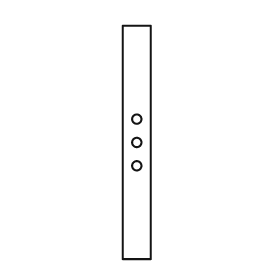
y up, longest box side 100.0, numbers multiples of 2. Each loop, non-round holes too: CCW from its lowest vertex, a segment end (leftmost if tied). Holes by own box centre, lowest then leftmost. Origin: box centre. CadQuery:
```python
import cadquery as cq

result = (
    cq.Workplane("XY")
    .moveTo(-6.0, -50.0)
    .lineTo(6.0, -50.0)
    .lineTo(6.0, 50.0)
    .lineTo(-6.0, 50.0)
    .close()
    .moveTo(0.0, -10.0)
    .circle(2.0)
    .moveTo(0.0, 0.0)
    .circle(2.0)
    .moveTo(0.0, 10.0)
    .circle(2.0)
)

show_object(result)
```